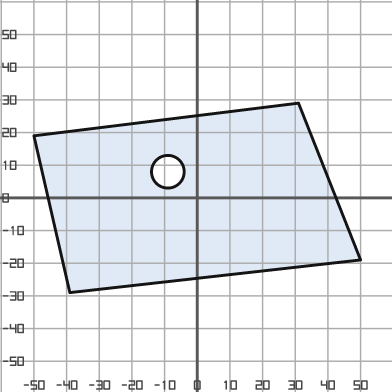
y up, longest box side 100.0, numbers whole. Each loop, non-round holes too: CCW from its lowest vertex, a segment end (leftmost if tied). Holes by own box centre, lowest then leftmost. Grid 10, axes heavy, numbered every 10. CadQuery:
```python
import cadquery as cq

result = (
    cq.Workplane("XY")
    .moveTo(-39.0, -29.0)
    .lineTo(50.0, -19.0)
    .lineTo(31.0, 29.0)
    .lineTo(-50.0, 19.0)
    .close()
    .moveTo(-9.0, 8.0)
    .circle(5.0)
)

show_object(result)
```